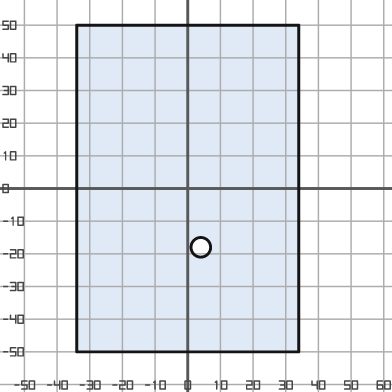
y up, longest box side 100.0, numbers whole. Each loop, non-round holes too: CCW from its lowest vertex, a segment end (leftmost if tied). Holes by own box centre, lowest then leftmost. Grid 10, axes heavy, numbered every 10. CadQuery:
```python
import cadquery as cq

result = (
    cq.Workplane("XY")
    .moveTo(-34.0, -50.0)
    .lineTo(34.0, -50.0)
    .lineTo(34.0, 50.0)
    .lineTo(-34.0, 50.0)
    .close()
    .moveTo(4.0, -18.0)
    .circle(3.0)
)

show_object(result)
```